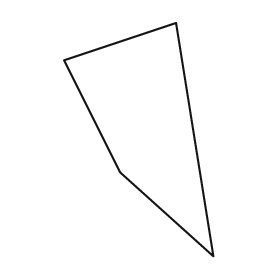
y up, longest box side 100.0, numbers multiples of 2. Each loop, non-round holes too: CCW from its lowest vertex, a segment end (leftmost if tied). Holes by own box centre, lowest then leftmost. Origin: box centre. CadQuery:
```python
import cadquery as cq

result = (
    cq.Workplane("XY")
    .moveTo(32.0, -50.0)
    .lineTo(16.0, 50.0)
    .lineTo(-32.0, 34.0)
    .lineTo(-8.0, -14.0)
    .close()
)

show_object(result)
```